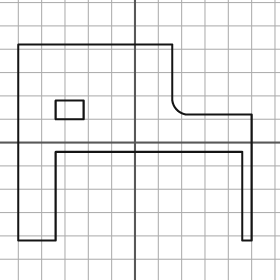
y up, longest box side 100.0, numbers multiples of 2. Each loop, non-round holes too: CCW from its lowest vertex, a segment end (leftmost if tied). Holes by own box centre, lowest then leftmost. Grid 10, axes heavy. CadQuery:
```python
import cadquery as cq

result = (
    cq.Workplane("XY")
    .moveTo(-50.0, -42.0)
    .lineTo(-34.0, -42.0)
    .lineTo(-34.0, -4.0)
    .lineTo(46.0, -4.0)
    .lineTo(46.0, -42.0)
    .lineTo(50.0, -42.0)
    .lineTo(50.0, 12.0)
    .lineTo(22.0, 12.0)
    .threePointArc((18.0, 14.0), (16.0, 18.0))
    .lineTo(16.0, 42.0)
    .lineTo(-50.0, 42.0)
    .close()
    .moveTo(-34.0, 10.0)
    .lineTo(-22.0, 10.0)
    .lineTo(-22.0, 18.0)
    .lineTo(-34.0, 18.0)
    .close()
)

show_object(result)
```